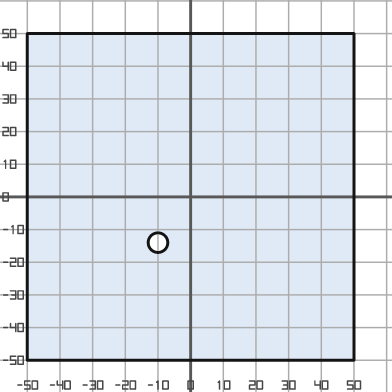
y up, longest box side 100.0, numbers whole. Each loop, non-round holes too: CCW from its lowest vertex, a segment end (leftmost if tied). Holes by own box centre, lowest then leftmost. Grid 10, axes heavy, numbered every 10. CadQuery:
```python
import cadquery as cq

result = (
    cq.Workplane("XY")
    .moveTo(-50.0, -50.0)
    .lineTo(50.0, -50.0)
    .lineTo(50.0, 50.0)
    .lineTo(-50.0, 50.0)
    .close()
    .moveTo(-10.0, -14.0)
    .circle(3.0)
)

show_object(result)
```